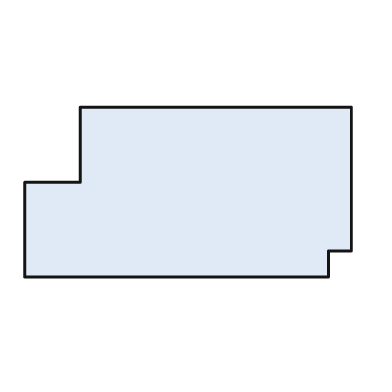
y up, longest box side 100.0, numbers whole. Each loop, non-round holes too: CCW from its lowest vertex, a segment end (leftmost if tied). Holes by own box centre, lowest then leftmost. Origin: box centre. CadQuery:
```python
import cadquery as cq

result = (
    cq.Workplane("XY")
    .moveTo(-50.0, -26.0)
    .lineTo(43.0, -26.0)
    .lineTo(43.0, -18.0)
    .lineTo(50.0, -18.0)
    .lineTo(50.0, 26.0)
    .lineTo(-33.0, 26.0)
    .lineTo(-33.0, 3.0)
    .lineTo(-50.0, 3.0)
    .close()
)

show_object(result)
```